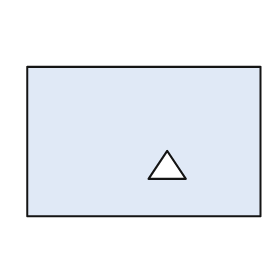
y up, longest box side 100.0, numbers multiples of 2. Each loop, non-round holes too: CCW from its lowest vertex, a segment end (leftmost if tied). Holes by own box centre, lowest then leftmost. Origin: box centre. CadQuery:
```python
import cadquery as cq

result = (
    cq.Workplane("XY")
    .moveTo(-50.0, -32.0)
    .lineTo(50.0, -32.0)
    .lineTo(50.0, 32.0)
    .lineTo(-50.0, 32.0)
    .close()
    .moveTo(2.0, -16.0)
    .lineTo(18.0, -16.0)
    .lineTo(10.0, -4.0)
    .close()
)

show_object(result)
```